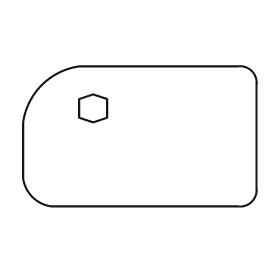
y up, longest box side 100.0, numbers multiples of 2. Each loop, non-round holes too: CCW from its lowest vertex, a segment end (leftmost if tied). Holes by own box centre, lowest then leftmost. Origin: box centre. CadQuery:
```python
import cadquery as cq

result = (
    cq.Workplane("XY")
    .moveTo(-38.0, -30.0)
    .lineTo(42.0, -30.0)
    .threePointArc((48.0, -28.0), (50.0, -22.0))
    .lineTo(50.0, 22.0)
    .threePointArc((48.0, 28.0), (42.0, 30.0))
    .lineTo(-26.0, 30.0)
    .threePointArc((-42.0, 22.0), (-50.0, 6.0))
    .lineTo(-50.0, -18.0)
    .threePointArc((-46.0, -26.0), (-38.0, -30.0))
    .close()
    .moveTo(-20.0, 6.0)
    .lineTo(-14.0, 8.0)
    .lineTo(-14.0, 16.0)
    .lineTo(-20.0, 18.0)
    .lineTo(-26.0, 16.0)
    .lineTo(-26.0, 8.0)
    .close()
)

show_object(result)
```